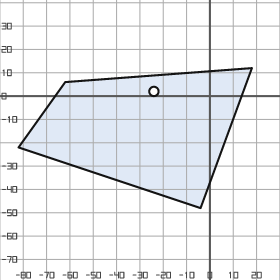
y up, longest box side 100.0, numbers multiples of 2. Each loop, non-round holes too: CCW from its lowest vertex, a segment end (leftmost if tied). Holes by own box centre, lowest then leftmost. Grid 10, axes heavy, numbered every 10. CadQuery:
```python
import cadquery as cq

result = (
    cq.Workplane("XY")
    .moveTo(-4.0, -48.0)
    .lineTo(18.0, 12.0)
    .lineTo(-62.0, 6.0)
    .lineTo(-82.0, -22.0)
    .close()
    .moveTo(-24.0, 2.0)
    .circle(2.0)
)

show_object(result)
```